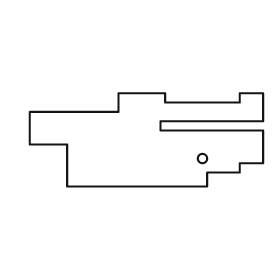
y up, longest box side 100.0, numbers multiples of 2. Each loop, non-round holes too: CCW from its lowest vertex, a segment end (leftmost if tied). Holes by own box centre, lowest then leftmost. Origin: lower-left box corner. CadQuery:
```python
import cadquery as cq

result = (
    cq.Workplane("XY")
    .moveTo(16.0, 0.0)
    .lineTo(76.0, 0.0)
    .lineTo(76.0, 6.0)
    .lineTo(90.0, 6.0)
    .lineTo(90.0, 10.0)
    .lineTo(100.0, 10.0)
    .lineTo(100.0, 24.0)
    .lineTo(56.0, 24.0)
    .lineTo(56.0, 28.0)
    .lineTo(100.0, 28.0)
    .lineTo(100.0, 40.0)
    .lineTo(90.0, 40.0)
    .lineTo(90.0, 36.0)
    .lineTo(58.0, 36.0)
    .lineTo(58.0, 40.0)
    .lineTo(38.0, 40.0)
    .lineTo(38.0, 32.0)
    .lineTo(0.0, 32.0)
    .lineTo(0.0, 18.0)
    .lineTo(16.0, 18.0)
    .close()
    .moveTo(74.0, 12.0)
    .circle(2.0)
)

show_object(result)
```